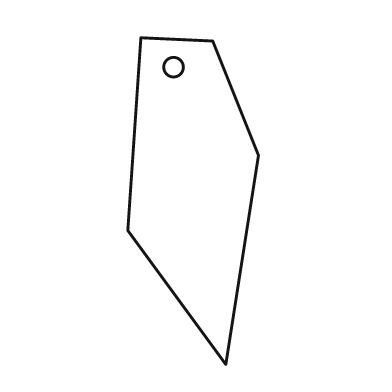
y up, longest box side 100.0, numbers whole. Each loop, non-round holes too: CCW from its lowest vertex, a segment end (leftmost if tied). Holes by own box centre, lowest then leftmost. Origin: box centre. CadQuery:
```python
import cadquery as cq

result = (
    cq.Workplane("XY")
    .moveTo(10.0, -50.0)
    .lineTo(20.0, 14.0)
    .lineTo(6.0, 49.0)
    .lineTo(-16.0, 50.0)
    .lineTo(-20.0, -9.0)
    .close()
    .moveTo(-6.0, 41.0)
    .circle(3.0)
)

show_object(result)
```